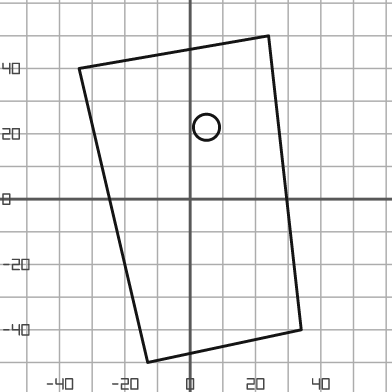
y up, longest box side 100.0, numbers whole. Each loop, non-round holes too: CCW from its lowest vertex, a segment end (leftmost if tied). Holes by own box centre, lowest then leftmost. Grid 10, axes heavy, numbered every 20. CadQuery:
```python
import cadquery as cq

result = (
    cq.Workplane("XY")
    .moveTo(-13.0, -50.0)
    .lineTo(34.0, -40.0)
    .lineTo(24.0, 50.0)
    .lineTo(-34.0, 40.0)
    .close()
    .moveTo(5.0, 22.0)
    .circle(4.0)
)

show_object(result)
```